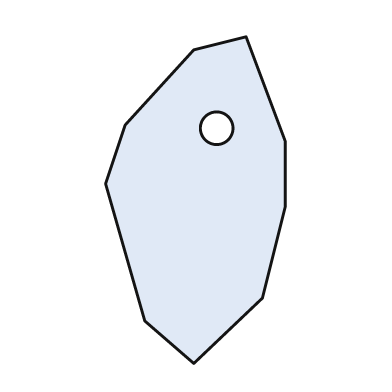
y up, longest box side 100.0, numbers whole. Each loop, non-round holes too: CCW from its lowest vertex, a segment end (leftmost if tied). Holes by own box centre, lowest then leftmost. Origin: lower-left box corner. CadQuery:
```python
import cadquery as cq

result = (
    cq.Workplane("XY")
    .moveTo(27.0, 0.0)
    .lineTo(48.0, 20.0)
    .lineTo(55.0, 48.0)
    .lineTo(55.0, 68.0)
    .lineTo(43.0, 100.0)
    .lineTo(27.0, 96.0)
    .lineTo(6.0, 73.0)
    .lineTo(0.0, 55.0)
    .lineTo(12.0, 13.0)
    .close()
    .moveTo(34.0, 72.0)
    .circle(5.0)
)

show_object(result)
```